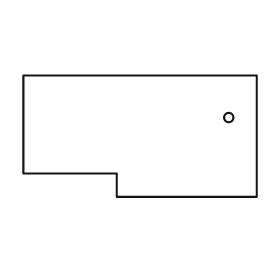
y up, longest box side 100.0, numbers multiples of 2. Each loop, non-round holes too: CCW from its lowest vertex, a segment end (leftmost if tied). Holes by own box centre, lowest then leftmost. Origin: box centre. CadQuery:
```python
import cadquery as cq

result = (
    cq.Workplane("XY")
    .moveTo(-10.0, -26.0)
    .lineTo(50.0, -26.0)
    .lineTo(50.0, 26.0)
    .lineTo(-50.0, 26.0)
    .lineTo(-50.0, -16.0)
    .lineTo(-10.0, -16.0)
    .close()
    .moveTo(38.0, 8.0)
    .circle(2.0)
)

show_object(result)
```